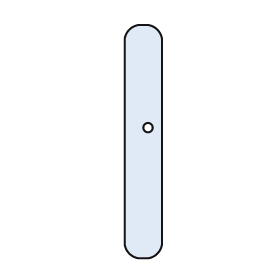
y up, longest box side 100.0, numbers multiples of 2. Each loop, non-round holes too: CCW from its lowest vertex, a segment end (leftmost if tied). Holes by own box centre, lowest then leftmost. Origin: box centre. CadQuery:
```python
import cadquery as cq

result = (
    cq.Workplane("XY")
    .moveTo(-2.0, -50.0)
    .lineTo(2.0, -50.0)
    .threePointArc((6.0, -48.0), (8.0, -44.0))
    .lineTo(8.0, 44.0)
    .threePointArc((6.0, 48.0), (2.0, 50.0))
    .lineTo(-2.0, 50.0)
    .threePointArc((-6.0, 48.0), (-8.0, 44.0))
    .lineTo(-8.0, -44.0)
    .threePointArc((-6.0, -48.0), (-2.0, -50.0))
    .close()
    .moveTo(2.0, 6.0)
    .circle(2.0)
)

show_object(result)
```